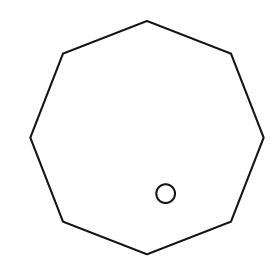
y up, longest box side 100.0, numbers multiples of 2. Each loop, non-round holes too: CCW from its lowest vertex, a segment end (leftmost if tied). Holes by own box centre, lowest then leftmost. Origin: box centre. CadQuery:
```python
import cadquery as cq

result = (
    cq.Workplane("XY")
    .moveTo(0.0, -50.0)
    .lineTo(36.0, -36.0)
    .lineTo(50.0, 0.0)
    .lineTo(36.0, 36.0)
    .lineTo(0.0, 50.0)
    .lineTo(-36.0, 36.0)
    .lineTo(-50.0, 0.0)
    .lineTo(-36.0, -36.0)
    .close()
    .moveTo(8.0, -24.0)
    .circle(4.0)
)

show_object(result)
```